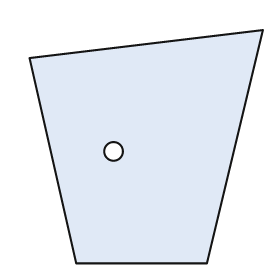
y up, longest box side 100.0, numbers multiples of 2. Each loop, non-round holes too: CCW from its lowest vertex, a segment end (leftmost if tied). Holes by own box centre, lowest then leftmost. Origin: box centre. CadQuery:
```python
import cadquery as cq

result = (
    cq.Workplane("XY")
    .moveTo(-30.0, -50.0)
    .lineTo(26.0, -50.0)
    .lineTo(50.0, 50.0)
    .lineTo(-50.0, 38.0)
    .close()
    .moveTo(-14.0, -2.0)
    .circle(4.0)
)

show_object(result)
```